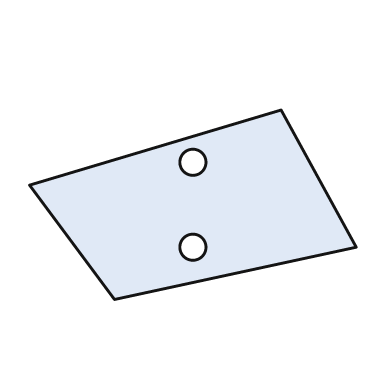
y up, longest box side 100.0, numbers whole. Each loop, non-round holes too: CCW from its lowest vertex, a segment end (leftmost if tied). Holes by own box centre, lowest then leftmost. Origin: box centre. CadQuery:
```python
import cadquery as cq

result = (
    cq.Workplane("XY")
    .moveTo(-24.0, -29.0)
    .lineTo(50.0, -13.0)
    .lineTo(27.0, 29.0)
    .lineTo(-50.0, 6.0)
    .close()
    .moveTo(0.0, -13.0)
    .circle(4.0)
    .moveTo(0.0, 13.0)
    .circle(4.0)
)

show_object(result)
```